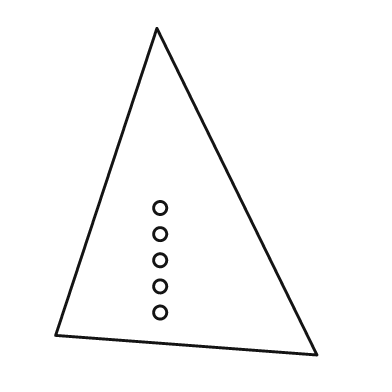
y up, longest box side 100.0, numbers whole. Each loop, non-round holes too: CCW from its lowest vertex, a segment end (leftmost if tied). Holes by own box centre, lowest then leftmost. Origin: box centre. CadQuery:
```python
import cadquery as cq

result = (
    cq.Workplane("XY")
    .moveTo(40.0, -50.0)
    .lineTo(-9.0, 50.0)
    .lineTo(-40.0, -44.0)
    .close()
    .moveTo(-8.0, -37.0)
    .circle(2.0)
    .moveTo(-8.0, -29.0)
    .circle(2.0)
    .moveTo(-8.0, -21.0)
    .circle(2.0)
    .moveTo(-8.0, -13.0)
    .circle(2.0)
    .moveTo(-8.0, -5.0)
    .circle(2.0)
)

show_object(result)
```